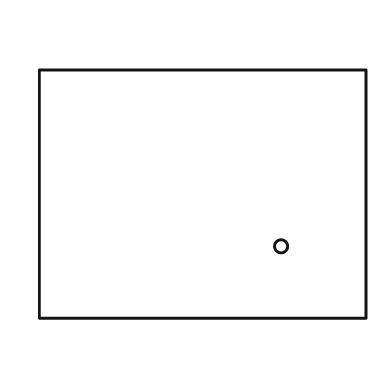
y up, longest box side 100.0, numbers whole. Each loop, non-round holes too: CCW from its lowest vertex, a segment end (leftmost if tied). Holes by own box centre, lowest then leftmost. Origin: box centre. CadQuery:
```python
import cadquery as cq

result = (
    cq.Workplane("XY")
    .moveTo(-50.0, -38.0)
    .lineTo(50.0, -38.0)
    .lineTo(50.0, 38.0)
    .lineTo(-50.0, 38.0)
    .close()
    .moveTo(24.0, -16.0)
    .circle(2.0)
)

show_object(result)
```